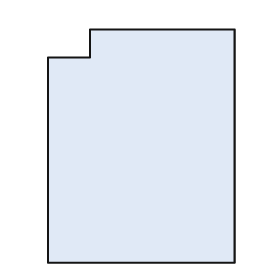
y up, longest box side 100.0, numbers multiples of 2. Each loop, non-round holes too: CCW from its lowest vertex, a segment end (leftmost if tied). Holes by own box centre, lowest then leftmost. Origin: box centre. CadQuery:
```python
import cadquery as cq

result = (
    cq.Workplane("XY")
    .moveTo(-40.0, -50.0)
    .lineTo(40.0, -50.0)
    .lineTo(40.0, 50.0)
    .lineTo(-22.0, 50.0)
    .lineTo(-22.0, 38.0)
    .lineTo(-40.0, 38.0)
    .close()
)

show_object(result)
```